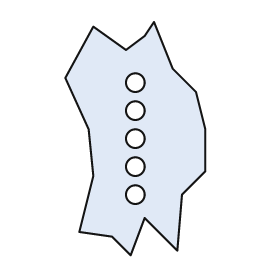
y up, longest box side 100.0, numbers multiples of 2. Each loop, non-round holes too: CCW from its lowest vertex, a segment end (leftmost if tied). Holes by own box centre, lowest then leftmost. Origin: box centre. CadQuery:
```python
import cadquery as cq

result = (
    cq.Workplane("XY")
    .moveTo(-2.0, -50.0)
    .lineTo(4.0, -34.0)
    .lineTo(18.0, -48.0)
    .lineTo(20.0, -24.0)
    .lineTo(30.0, -14.0)
    .lineTo(30.0, 4.0)
    .lineTo(26.0, 20.0)
    .lineTo(16.0, 30.0)
    .lineTo(8.0, 50.0)
    .lineTo(4.0, 44.0)
    .lineTo(-4.0, 38.0)
    .lineTo(-18.0, 48.0)
    .lineTo(-30.0, 26.0)
    .lineTo(-20.0, 4.0)
    .lineTo(-18.0, -16.0)
    .lineTo(-24.0, -40.0)
    .lineTo(-10.0, -42.0)
    .close()
    .moveTo(0.0, -24.0)
    .circle(4.0)
    .moveTo(0.0, -12.0)
    .circle(4.0)
    .moveTo(0.0, 0.0)
    .circle(4.0)
    .moveTo(0.0, 12.0)
    .circle(4.0)
    .moveTo(0.0, 24.0)
    .circle(4.0)
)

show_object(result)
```